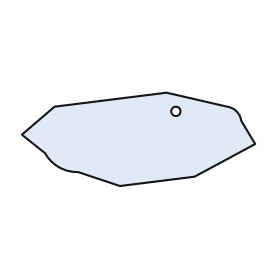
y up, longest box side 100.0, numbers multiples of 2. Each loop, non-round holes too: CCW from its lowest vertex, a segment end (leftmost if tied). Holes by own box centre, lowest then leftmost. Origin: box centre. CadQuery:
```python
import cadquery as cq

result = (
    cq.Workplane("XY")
    .moveTo(-8.0, -20.0)
    .lineTo(24.0, -16.0)
    .lineTo(50.0, -2.0)
    .lineTo(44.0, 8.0)
    .threePointArc((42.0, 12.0), (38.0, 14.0))
    .lineTo(12.0, 20.0)
    .lineTo(-36.0, 14.0)
    .lineTo(-50.0, 2.0)
    .lineTo(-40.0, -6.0)
    .threePointArc((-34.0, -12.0), (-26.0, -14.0))
    .close()
    .moveTo(16.0, 12.0)
    .circle(2.0)
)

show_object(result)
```